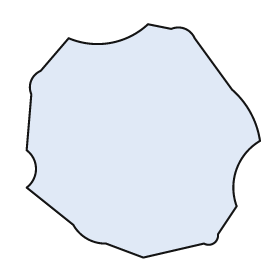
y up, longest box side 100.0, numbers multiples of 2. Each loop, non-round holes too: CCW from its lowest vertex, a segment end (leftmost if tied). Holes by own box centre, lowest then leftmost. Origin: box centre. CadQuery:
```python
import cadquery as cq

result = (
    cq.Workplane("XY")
    .moveTo(0.0, -50.0)
    .lineTo(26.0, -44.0)
    .threePointArc((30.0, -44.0), (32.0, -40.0))
    .lineTo(40.0, -28.0)
    .threePointArc((40.0, -12.0), (50.0, 0.0))
    .threePointArc((46.0, 12.0), (38.0, 22.0))
    .lineTo(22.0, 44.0)
    .threePointArc((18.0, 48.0), (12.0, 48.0))
    .lineTo(2.0, 50.0)
    .threePointArc((-14.0, 42.0), (-32.0, 44.0))
    .lineTo(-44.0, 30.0)
    .threePointArc((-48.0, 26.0), (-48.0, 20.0))
    .lineTo(-50.0, -4.0)
    .threePointArc((-46.0, -12.0), (-50.0, -20.0))
    .lineTo(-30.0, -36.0)
    .threePointArc((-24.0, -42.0), (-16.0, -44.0))
    .close()
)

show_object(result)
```